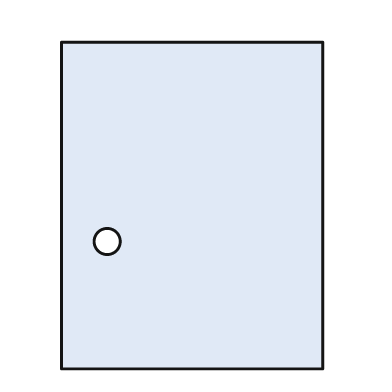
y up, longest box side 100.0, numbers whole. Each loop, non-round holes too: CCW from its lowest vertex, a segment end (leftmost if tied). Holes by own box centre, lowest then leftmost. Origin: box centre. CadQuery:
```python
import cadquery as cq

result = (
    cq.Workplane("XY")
    .moveTo(-40.0, -50.0)
    .lineTo(40.0, -50.0)
    .lineTo(40.0, 50.0)
    .lineTo(-40.0, 50.0)
    .close()
    .moveTo(-26.0, -11.0)
    .circle(4.0)
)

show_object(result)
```